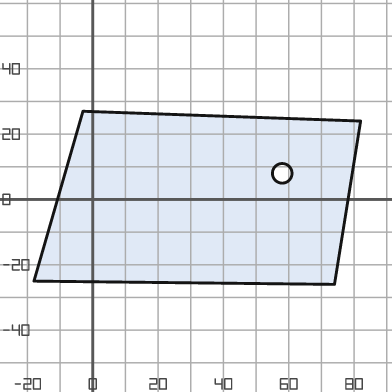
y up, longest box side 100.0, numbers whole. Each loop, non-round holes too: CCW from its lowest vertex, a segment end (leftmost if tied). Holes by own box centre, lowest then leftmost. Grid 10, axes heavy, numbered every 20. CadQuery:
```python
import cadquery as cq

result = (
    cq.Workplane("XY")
    .moveTo(74.0, -26.0)
    .lineTo(82.0, 24.0)
    .lineTo(-3.0, 27.0)
    .lineTo(-18.0, -25.0)
    .close()
    .moveTo(58.0, 8.0)
    .circle(3.0)
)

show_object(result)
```